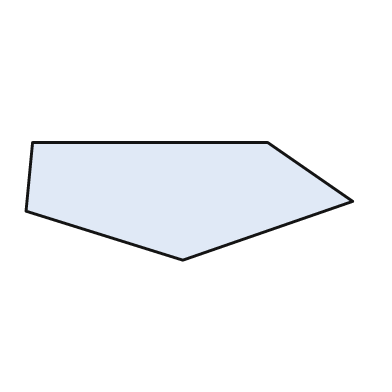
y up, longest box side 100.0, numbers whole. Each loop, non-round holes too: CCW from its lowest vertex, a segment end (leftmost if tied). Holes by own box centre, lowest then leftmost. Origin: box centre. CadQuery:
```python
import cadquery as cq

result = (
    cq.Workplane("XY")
    .moveTo(-2.0, -18.0)
    .lineTo(50.0, 0.0)
    .lineTo(24.0, 18.0)
    .lineTo(-48.0, 18.0)
    .lineTo(-50.0, -3.0)
    .close()
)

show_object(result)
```